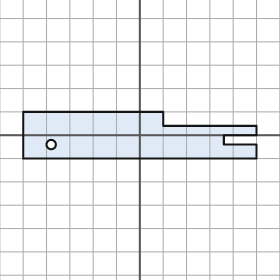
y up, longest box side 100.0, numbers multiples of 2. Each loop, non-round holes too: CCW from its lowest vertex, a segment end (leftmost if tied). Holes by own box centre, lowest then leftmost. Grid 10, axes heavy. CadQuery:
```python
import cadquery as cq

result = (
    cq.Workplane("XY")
    .moveTo(-50.0, -10.0)
    .lineTo(50.0, -10.0)
    .lineTo(50.0, -4.0)
    .lineTo(36.0, -4.0)
    .lineTo(36.0, 0.0)
    .lineTo(50.0, 0.0)
    .lineTo(50.0, 4.0)
    .lineTo(10.0, 4.0)
    .lineTo(10.0, 10.0)
    .lineTo(-50.0, 10.0)
    .close()
    .moveTo(-38.0, -4.0)
    .circle(2.0)
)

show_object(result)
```